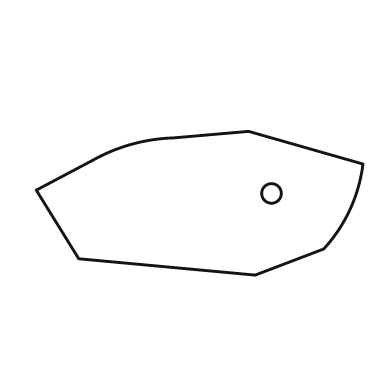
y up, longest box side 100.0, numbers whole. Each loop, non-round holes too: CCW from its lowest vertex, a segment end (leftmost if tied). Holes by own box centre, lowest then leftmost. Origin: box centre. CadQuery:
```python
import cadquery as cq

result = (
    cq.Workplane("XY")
    .moveTo(17.0, -22.0)
    .lineTo(38.0, -14.0)
    .threePointArc((46.0, -2.0), (50.0, 12.0))
    .lineTo(15.0, 22.0)
    .lineTo(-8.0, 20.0)
    .threePointArc((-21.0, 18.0), (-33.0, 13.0))
    .lineTo(-50.0, 4.0)
    .lineTo(-37.0, -17.0)
    .close()
    .moveTo(22.0, 3.0)
    .circle(3.0)
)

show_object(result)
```